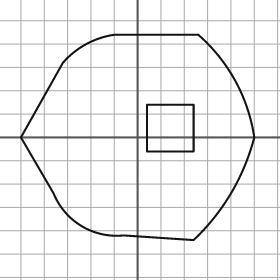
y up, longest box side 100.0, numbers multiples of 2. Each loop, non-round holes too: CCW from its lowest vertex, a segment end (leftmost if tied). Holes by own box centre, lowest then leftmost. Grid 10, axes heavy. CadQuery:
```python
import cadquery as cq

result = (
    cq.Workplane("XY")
    .moveTo(24.0, -44.0)
    .threePointArc((40.0, -24.0), (50.0, 0.0))
    .threePointArc((42.0, 24.0), (26.0, 44.0))
    .lineTo(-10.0, 44.0)
    .threePointArc((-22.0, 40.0), (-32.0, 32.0))
    .lineTo(-50.0, 0.0)
    .lineTo(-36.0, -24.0)
    .threePointArc((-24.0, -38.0), (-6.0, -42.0))
    .close()
    .moveTo(4.0, -6.0)
    .lineTo(24.0, -6.0)
    .lineTo(24.0, 14.0)
    .lineTo(4.0, 14.0)
    .close()
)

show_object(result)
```